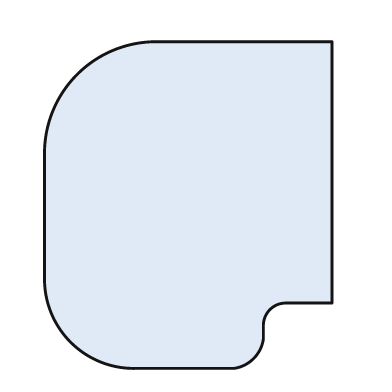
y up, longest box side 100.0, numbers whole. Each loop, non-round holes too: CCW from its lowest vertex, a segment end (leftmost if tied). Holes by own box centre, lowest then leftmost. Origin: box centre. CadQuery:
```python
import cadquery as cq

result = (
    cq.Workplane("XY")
    .moveTo(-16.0, -50.0)
    .lineTo(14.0, -50.0)
    .threePointArc((20.0, -47.0), (23.0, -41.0))
    .lineTo(23.0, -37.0)
    .threePointArc((25.0, -32.0), (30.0, -30.0))
    .lineTo(44.0, -30.0)
    .lineTo(44.0, 50.0)
    .lineTo(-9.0, 50.0)
    .threePointArc((-34.0, 40.0), (-44.0, 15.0))
    .lineTo(-44.0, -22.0)
    .threePointArc((-36.0, -42.0), (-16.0, -50.0))
    .close()
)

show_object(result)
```